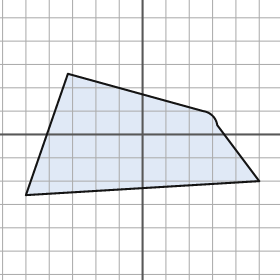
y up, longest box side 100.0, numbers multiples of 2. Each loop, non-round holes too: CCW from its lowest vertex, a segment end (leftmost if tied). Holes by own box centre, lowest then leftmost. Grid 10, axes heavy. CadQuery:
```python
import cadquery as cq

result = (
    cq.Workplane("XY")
    .moveTo(-50.0, -26.0)
    .lineTo(50.0, -20.0)
    .lineTo(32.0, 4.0)
    .threePointArc((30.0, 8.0), (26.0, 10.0))
    .lineTo(-32.0, 26.0)
    .close()
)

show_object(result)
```